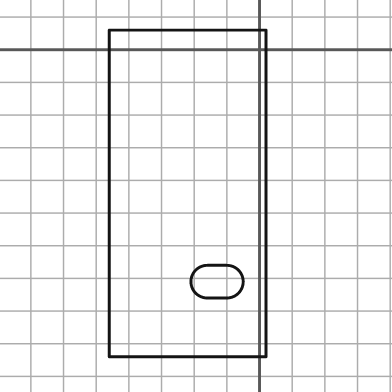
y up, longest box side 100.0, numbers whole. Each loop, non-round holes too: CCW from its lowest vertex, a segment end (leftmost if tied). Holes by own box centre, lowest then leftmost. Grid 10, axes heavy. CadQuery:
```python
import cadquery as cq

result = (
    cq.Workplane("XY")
    .moveTo(-46.0, -94.0)
    .lineTo(2.0, -94.0)
    .lineTo(2.0, 6.0)
    .lineTo(-46.0, 6.0)
    .close()
    .moveTo(-16.0, -76.0)
    .lineTo(-10.0, -76.0)
    .threePointArc((-5.0, -71.0), (-10.0, -66.0))
    .lineTo(-16.0, -66.0)
    .threePointArc((-21.0, -71.0), (-16.0, -76.0))
    .close()
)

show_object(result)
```